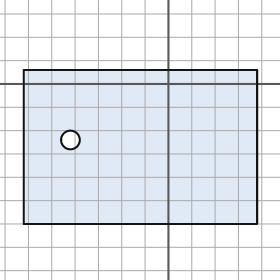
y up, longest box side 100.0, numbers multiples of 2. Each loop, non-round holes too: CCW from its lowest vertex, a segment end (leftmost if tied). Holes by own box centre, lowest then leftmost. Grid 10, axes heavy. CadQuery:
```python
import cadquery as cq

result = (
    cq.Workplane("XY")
    .moveTo(-62.0, -60.0)
    .lineTo(38.0, -60.0)
    .lineTo(38.0, 6.0)
    .lineTo(-62.0, 6.0)
    .close()
    .moveTo(-42.0, -24.0)
    .circle(4.0)
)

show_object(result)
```